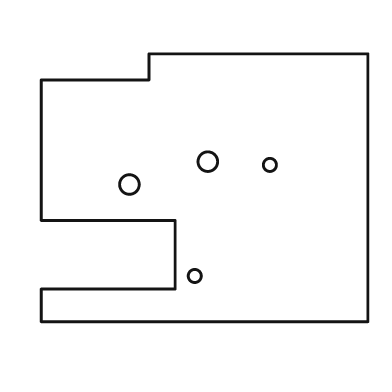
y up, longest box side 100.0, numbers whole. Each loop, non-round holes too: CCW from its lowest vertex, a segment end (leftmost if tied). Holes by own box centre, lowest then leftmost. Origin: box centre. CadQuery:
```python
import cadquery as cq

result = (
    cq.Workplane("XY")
    .moveTo(-50.0, -41.0)
    .lineTo(50.0, -41.0)
    .lineTo(50.0, 41.0)
    .lineTo(-17.0, 41.0)
    .lineTo(-17.0, 33.0)
    .lineTo(-50.0, 33.0)
    .lineTo(-50.0, -10.0)
    .lineTo(-9.0, -10.0)
    .lineTo(-9.0, -31.0)
    .lineTo(-50.0, -31.0)
    .close()
    .moveTo(-3.0, -27.0)
    .circle(2.0)
    .moveTo(-23.0, 1.0)
    .circle(3.0)
    .moveTo(20.0, 7.0)
    .circle(2.0)
    .moveTo(1.0, 8.0)
    .circle(3.0)
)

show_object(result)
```